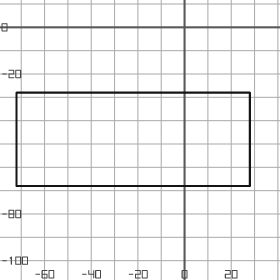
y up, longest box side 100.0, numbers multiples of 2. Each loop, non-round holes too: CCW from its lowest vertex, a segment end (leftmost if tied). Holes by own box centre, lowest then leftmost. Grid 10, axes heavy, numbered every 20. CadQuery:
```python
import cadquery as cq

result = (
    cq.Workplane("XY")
    .moveTo(-72.0, -68.0)
    .lineTo(28.0, -68.0)
    .lineTo(28.0, -28.0)
    .lineTo(-72.0, -28.0)
    .close()
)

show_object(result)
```